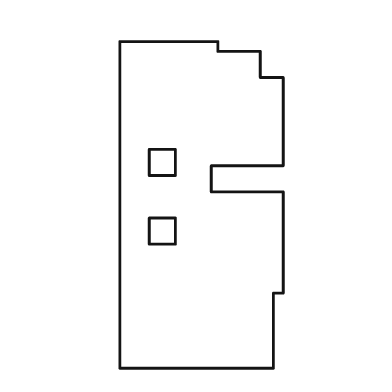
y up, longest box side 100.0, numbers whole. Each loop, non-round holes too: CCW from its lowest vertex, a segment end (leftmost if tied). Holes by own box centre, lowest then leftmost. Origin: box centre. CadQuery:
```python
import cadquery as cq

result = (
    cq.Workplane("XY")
    .moveTo(-25.0, -50.0)
    .lineTo(22.0, -50.0)
    .lineTo(22.0, -27.0)
    .lineTo(25.0, -27.0)
    .lineTo(25.0, 4.0)
    .lineTo(3.0, 4.0)
    .lineTo(3.0, 12.0)
    .lineTo(25.0, 12.0)
    .lineTo(25.0, 39.0)
    .lineTo(18.0, 39.0)
    .lineTo(18.0, 47.0)
    .lineTo(5.0, 47.0)
    .lineTo(5.0, 50.0)
    .lineTo(-25.0, 50.0)
    .close()
    .moveTo(-16.0, -12.0)
    .lineTo(-8.0, -12.0)
    .lineTo(-8.0, -4.0)
    .lineTo(-16.0, -4.0)
    .close()
    .moveTo(-16.0, 9.0)
    .lineTo(-8.0, 9.0)
    .lineTo(-8.0, 17.0)
    .lineTo(-16.0, 17.0)
    .close()
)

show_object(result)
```